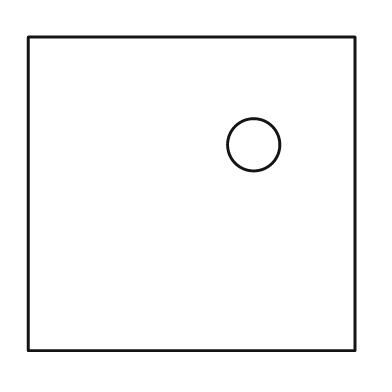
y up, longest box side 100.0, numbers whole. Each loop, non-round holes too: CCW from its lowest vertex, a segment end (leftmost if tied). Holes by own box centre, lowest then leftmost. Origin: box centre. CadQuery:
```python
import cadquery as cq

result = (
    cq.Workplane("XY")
    .moveTo(-50.0, -48.0)
    .lineTo(50.0, -48.0)
    .lineTo(50.0, 48.0)
    .lineTo(-50.0, 48.0)
    .close()
    .moveTo(19.0, 15.0)
    .circle(8.0)
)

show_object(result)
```